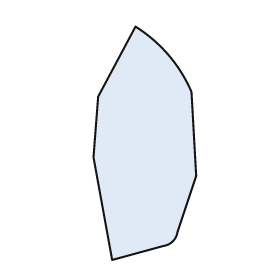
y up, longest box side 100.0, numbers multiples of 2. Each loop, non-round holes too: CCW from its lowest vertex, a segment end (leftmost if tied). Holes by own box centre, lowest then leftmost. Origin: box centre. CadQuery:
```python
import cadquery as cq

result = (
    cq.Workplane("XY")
    .moveTo(-14.0, -50.0)
    .lineTo(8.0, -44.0)
    .threePointArc((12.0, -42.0), (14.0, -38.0))
    .lineTo(22.0, -14.0)
    .lineTo(20.0, 22.0)
    .threePointArc((10.0, 38.0), (-4.0, 50.0))
    .lineTo(-20.0, 20.0)
    .lineTo(-22.0, -6.0)
    .close()
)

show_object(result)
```